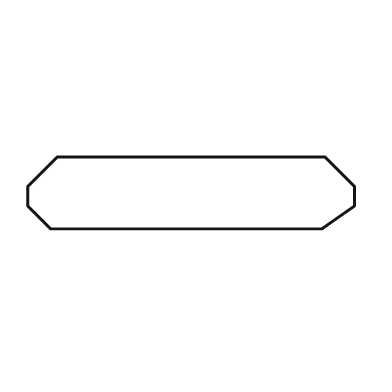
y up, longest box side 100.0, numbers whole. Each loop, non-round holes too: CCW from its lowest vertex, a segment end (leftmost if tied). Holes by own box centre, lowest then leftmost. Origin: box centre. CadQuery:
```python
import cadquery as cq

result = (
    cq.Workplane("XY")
    .moveTo(-43.0, -11.0)
    .lineTo(40.0, -11.0)
    .lineTo(50.0, -4.0)
    .lineTo(50.0, 2.0)
    .lineTo(41.0, 11.0)
    .lineTo(-41.0, 11.0)
    .lineTo(-50.0, 2.0)
    .lineTo(-50.0, -4.0)
    .close()
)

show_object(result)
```